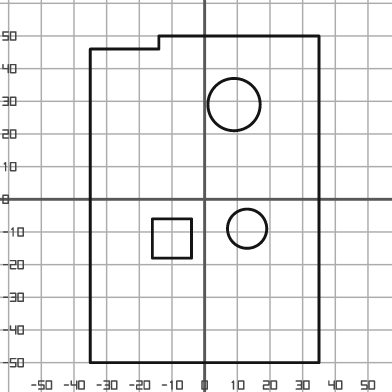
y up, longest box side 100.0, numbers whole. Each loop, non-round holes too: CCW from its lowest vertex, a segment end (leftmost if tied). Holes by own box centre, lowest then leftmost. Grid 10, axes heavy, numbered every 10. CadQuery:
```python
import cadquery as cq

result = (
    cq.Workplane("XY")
    .moveTo(-35.0, -50.0)
    .lineTo(35.0, -50.0)
    .lineTo(35.0, 50.0)
    .lineTo(-14.0, 50.0)
    .lineTo(-14.0, 46.0)
    .lineTo(-35.0, 46.0)
    .close()
    .moveTo(-16.0, -18.0)
    .lineTo(-4.0, -18.0)
    .lineTo(-4.0, -6.0)
    .lineTo(-16.0, -6.0)
    .close()
    .moveTo(13.0, -9.0)
    .circle(6.0)
    .moveTo(9.0, 29.0)
    .circle(8.0)
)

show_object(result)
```